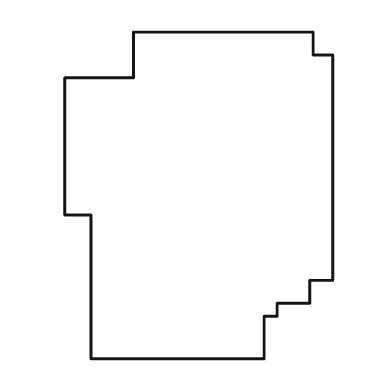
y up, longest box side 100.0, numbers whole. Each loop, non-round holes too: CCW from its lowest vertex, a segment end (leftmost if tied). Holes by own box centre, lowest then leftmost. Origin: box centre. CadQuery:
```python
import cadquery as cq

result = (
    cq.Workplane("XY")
    .moveTo(-33.0, -50.0)
    .lineTo(20.0, -50.0)
    .lineTo(20.0, -37.0)
    .lineTo(24.0, -37.0)
    .lineTo(24.0, -33.0)
    .lineTo(34.0, -33.0)
    .lineTo(34.0, -26.0)
    .lineTo(41.0, -26.0)
    .lineTo(41.0, 43.0)
    .lineTo(35.0, 43.0)
    .lineTo(35.0, 50.0)
    .lineTo(-20.0, 50.0)
    .lineTo(-20.0, 36.0)
    .lineTo(-41.0, 36.0)
    .lineTo(-41.0, -6.0)
    .lineTo(-33.0, -6.0)
    .close()
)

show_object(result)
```